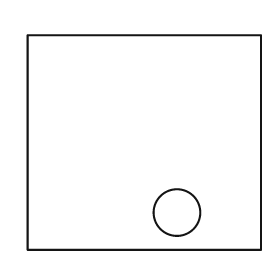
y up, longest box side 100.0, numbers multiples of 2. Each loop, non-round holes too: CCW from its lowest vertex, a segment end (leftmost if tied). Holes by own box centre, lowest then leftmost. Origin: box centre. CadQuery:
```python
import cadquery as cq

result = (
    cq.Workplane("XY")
    .moveTo(-50.0, -46.0)
    .lineTo(50.0, -46.0)
    .lineTo(50.0, 46.0)
    .lineTo(-50.0, 46.0)
    .close()
    .moveTo(14.0, -30.0)
    .circle(10.0)
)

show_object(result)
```